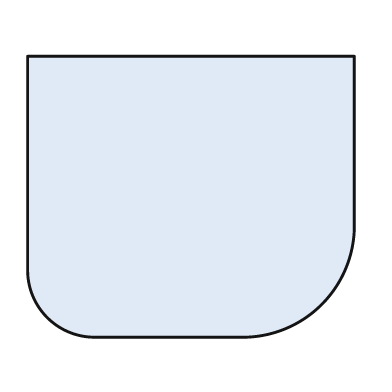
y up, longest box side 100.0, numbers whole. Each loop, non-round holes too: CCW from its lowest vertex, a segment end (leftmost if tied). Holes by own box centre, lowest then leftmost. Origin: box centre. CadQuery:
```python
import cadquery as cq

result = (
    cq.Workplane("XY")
    .moveTo(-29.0, -43.0)
    .lineTo(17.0, -43.0)
    .threePointArc((40.0, -33.0), (50.0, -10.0))
    .lineTo(50.0, 43.0)
    .lineTo(-50.0, 43.0)
    .lineTo(-50.0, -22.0)
    .threePointArc((-44.0, -37.0), (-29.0, -43.0))
    .close()
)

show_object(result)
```